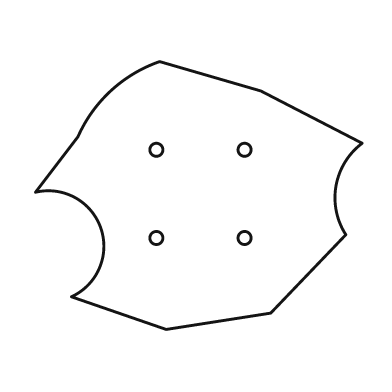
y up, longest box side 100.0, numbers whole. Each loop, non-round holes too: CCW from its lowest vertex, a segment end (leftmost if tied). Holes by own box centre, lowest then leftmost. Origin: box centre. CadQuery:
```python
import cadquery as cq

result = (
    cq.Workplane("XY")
    .moveTo(-10.0, -41.0)
    .lineTo(22.0, -36.0)
    .lineTo(45.0, -12.0)
    .threePointArc((42.0, 3.0), (50.0, 16.0))
    .lineTo(19.0, 32.0)
    .lineTo(-12.0, 41.0)
    .threePointArc((-27.0, 32.0), (-37.0, 18.0))
    .lineTo(-50.0, 1.0)
    .threePointArc((-30.0, -10.0), (-39.0, -31.0))
    .close()
    .moveTo(-13.0, -13.0)
    .circle(2.0)
    .moveTo(14.0, -13.0)
    .circle(2.0)
    .moveTo(-13.0, 14.0)
    .circle(2.0)
    .moveTo(14.0, 14.0)
    .circle(2.0)
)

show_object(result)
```